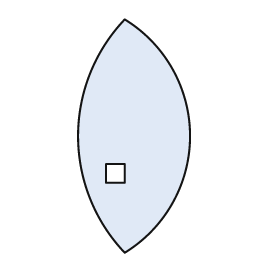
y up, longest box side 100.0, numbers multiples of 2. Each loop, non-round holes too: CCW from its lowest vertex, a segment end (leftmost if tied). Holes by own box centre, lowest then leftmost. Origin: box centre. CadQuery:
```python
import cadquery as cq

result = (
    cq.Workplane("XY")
    .moveTo(-4.0, -50.0)
    .threePointArc((24.0, 0.0), (-4.0, 50.0))
    .threePointArc((-24.0, 0.0), (-4.0, -50.0))
    .close()
    .moveTo(-12.0, -20.0)
    .lineTo(-4.0, -20.0)
    .lineTo(-4.0, -12.0)
    .lineTo(-12.0, -12.0)
    .close()
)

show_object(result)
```